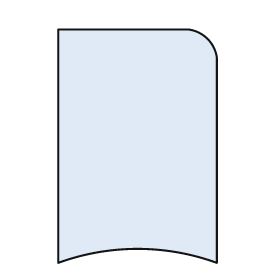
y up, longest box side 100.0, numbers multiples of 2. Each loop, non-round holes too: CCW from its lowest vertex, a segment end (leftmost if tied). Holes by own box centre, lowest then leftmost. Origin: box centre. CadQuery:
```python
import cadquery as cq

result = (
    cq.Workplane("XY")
    .moveTo(-34.0, -50.0)
    .threePointArc((0.0, -44.0), (34.0, -50.0))
    .lineTo(34.0, 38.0)
    .threePointArc((30.0, 46.0), (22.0, 50.0))
    .lineTo(-34.0, 50.0)
    .close()
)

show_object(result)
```